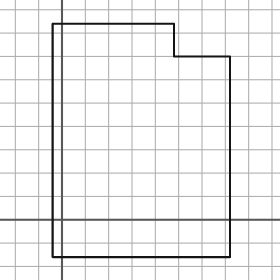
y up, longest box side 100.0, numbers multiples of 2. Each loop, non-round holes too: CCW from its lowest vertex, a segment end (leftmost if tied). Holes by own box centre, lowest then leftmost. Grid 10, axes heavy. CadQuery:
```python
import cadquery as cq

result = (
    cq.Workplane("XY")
    .moveTo(-4.0, -16.0)
    .lineTo(72.0, -16.0)
    .lineTo(72.0, 70.0)
    .lineTo(48.0, 70.0)
    .lineTo(48.0, 84.0)
    .lineTo(-4.0, 84.0)
    .close()
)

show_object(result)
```